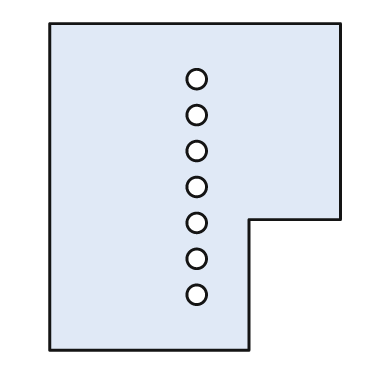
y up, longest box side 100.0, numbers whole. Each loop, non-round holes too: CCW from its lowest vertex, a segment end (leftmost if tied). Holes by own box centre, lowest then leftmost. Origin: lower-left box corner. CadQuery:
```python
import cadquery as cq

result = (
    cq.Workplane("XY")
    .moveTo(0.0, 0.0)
    .lineTo(61.0, 0.0)
    .lineTo(61.0, 40.0)
    .lineTo(89.0, 40.0)
    .lineTo(89.0, 100.0)
    .lineTo(0.0, 100.0)
    .close()
    .moveTo(45.0, 17.0)
    .circle(3.0)
    .moveTo(45.0, 28.0)
    .circle(3.0)
    .moveTo(45.0, 39.0)
    .circle(3.0)
    .moveTo(45.0, 50.0)
    .circle(3.0)
    .moveTo(45.0, 61.0)
    .circle(3.0)
    .moveTo(45.0, 72.0)
    .circle(3.0)
    .moveTo(45.0, 83.0)
    .circle(3.0)
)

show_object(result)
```